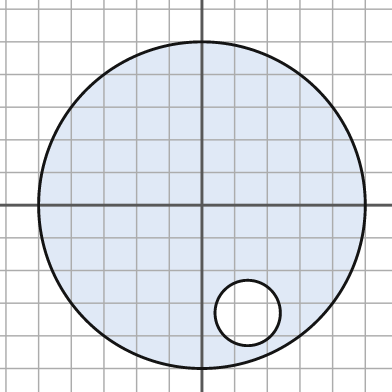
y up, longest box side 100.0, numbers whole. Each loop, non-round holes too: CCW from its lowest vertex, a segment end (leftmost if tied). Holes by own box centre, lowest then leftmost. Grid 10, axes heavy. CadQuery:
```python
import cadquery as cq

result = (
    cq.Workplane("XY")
    .moveTo(0.0, 0.0)
    .circle(50.0)
    .moveTo(14.0, -33.0)
    .circle(10.0)
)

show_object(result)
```